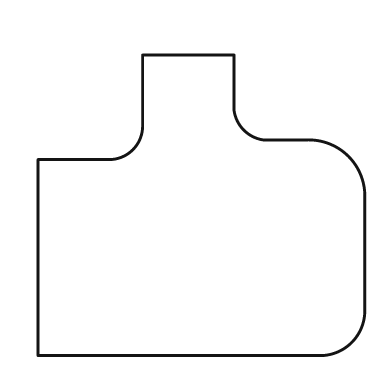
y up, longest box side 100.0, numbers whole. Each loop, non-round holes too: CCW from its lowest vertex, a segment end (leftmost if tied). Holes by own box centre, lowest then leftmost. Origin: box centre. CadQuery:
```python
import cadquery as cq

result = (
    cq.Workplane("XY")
    .moveTo(-50.0, -46.0)
    .lineTo(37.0, -46.0)
    .threePointArc((46.0, -42.0), (50.0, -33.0))
    .lineTo(50.0, 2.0)
    .threePointArc((45.0, 15.0), (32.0, 20.0))
    .lineTo(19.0, 20.0)
    .threePointArc((13.0, 23.0), (10.0, 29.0))
    .lineTo(10.0, 46.0)
    .lineTo(-18.0, 46.0)
    .lineTo(-18.0, 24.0)
    .threePointArc((-21.0, 17.0), (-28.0, 14.0))
    .lineTo(-50.0, 14.0)
    .close()
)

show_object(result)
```